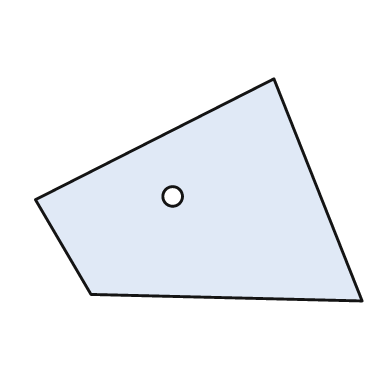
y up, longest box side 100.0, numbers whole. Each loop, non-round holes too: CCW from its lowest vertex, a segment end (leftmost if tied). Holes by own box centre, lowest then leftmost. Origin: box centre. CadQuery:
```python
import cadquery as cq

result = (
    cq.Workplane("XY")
    .moveTo(50.0, -34.0)
    .lineTo(23.0, 34.0)
    .lineTo(-50.0, -3.0)
    .lineTo(-33.0, -32.0)
    .close()
    .moveTo(-8.0, -2.0)
    .circle(3.0)
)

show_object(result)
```